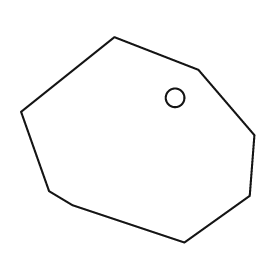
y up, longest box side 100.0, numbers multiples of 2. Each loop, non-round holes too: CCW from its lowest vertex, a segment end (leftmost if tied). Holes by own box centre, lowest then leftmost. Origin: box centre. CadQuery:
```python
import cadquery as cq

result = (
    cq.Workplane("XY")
    .moveTo(20.0, -44.0)
    .lineTo(48.0, -24.0)
    .lineTo(50.0, 2.0)
    .lineTo(26.0, 30.0)
    .lineTo(-10.0, 44.0)
    .lineTo(-50.0, 12.0)
    .lineTo(-38.0, -22.0)
    .lineTo(-28.0, -28.0)
    .close()
    .moveTo(16.0, 18.0)
    .circle(4.0)
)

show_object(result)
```